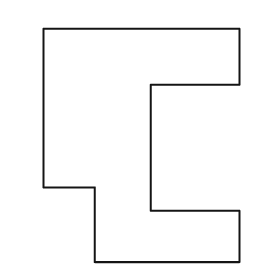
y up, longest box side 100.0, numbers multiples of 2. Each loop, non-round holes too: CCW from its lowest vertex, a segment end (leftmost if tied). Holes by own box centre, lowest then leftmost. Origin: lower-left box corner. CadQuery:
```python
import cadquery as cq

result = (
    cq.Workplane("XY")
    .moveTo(22.0, 0.0)
    .lineTo(84.0, 0.0)
    .lineTo(84.0, 22.0)
    .lineTo(46.0, 22.0)
    .lineTo(46.0, 76.0)
    .lineTo(84.0, 76.0)
    .lineTo(84.0, 100.0)
    .lineTo(0.0, 100.0)
    .lineTo(0.0, 32.0)
    .lineTo(22.0, 32.0)
    .close()
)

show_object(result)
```